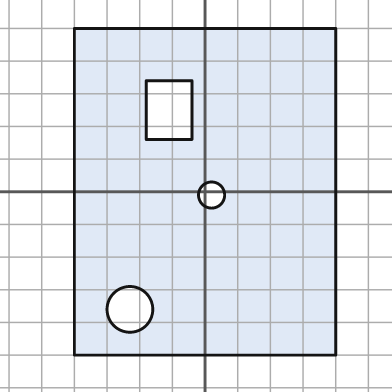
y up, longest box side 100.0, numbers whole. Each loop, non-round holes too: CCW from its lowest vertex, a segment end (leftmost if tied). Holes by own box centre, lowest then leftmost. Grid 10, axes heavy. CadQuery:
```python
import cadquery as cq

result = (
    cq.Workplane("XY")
    .moveTo(-40.0, -50.0)
    .lineTo(40.0, -50.0)
    .lineTo(40.0, 50.0)
    .lineTo(-40.0, 50.0)
    .close()
    .moveTo(-23.0, -36.0)
    .circle(7.0)
    .moveTo(2.0, -1.0)
    .circle(4.0)
    .moveTo(-18.0, 16.0)
    .lineTo(-4.0, 16.0)
    .lineTo(-4.0, 34.0)
    .lineTo(-18.0, 34.0)
    .close()
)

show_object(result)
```